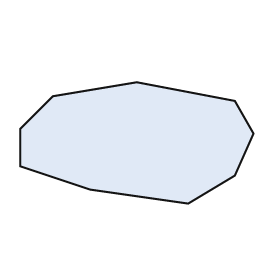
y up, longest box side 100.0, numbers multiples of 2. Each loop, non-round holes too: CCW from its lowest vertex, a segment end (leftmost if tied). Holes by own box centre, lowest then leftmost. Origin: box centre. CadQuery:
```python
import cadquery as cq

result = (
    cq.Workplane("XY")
    .moveTo(22.0, -26.0)
    .lineTo(42.0, -14.0)
    .lineTo(50.0, 4.0)
    .lineTo(42.0, 18.0)
    .lineTo(0.0, 26.0)
    .lineTo(-36.0, 20.0)
    .lineTo(-50.0, 6.0)
    .lineTo(-50.0, -10.0)
    .lineTo(-20.0, -20.0)
    .close()
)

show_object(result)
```